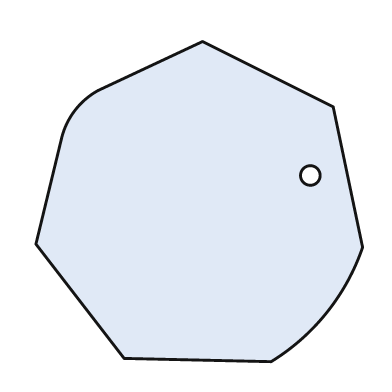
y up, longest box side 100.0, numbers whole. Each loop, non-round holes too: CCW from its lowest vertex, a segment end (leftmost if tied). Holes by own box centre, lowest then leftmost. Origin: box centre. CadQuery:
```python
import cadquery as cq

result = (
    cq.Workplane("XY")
    .moveTo(22.0, -49.0)
    .threePointArc((39.0, -34.0), (50.0, -14.0))
    .lineTo(41.0, 29.0)
    .lineTo(1.0, 49.0)
    .lineTo(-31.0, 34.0)
    .threePointArc((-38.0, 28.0), (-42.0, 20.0))
    .lineTo(-50.0, -13.0)
    .lineTo(-23.0, -48.0)
    .close()
    .moveTo(34.0, 8.0)
    .circle(3.0)
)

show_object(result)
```